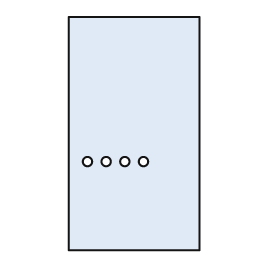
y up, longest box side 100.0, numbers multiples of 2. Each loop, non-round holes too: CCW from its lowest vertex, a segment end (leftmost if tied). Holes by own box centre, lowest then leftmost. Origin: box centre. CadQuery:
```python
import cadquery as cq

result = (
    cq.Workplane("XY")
    .moveTo(-28.0, -50.0)
    .lineTo(28.0, -50.0)
    .lineTo(28.0, 50.0)
    .lineTo(-28.0, 50.0)
    .close()
    .moveTo(-20.0, -12.0)
    .circle(2.0)
    .moveTo(-12.0, -12.0)
    .circle(2.0)
    .moveTo(-4.0, -12.0)
    .circle(2.0)
    .moveTo(4.0, -12.0)
    .circle(2.0)
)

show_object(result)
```